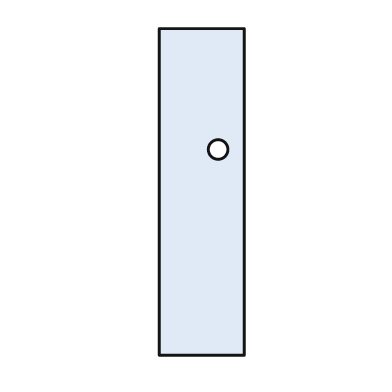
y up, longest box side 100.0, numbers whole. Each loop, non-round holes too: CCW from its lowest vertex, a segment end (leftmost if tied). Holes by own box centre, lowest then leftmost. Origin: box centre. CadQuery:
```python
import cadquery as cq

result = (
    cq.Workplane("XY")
    .moveTo(-13.0, -50.0)
    .lineTo(13.0, -50.0)
    .lineTo(13.0, 50.0)
    .lineTo(-13.0, 50.0)
    .close()
    .moveTo(5.0, 13.0)
    .circle(3.0)
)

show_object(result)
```